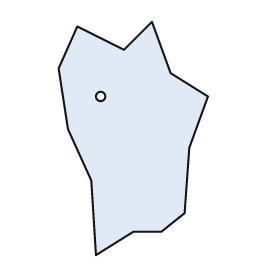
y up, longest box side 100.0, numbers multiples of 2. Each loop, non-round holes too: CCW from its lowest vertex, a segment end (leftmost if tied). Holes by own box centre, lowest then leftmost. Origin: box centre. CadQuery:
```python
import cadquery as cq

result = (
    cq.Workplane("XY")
    .moveTo(-16.0, -50.0)
    .lineTo(0.0, -40.0)
    .lineTo(12.0, -40.0)
    .lineTo(22.0, -32.0)
    .lineTo(24.0, -4.0)
    .lineTo(32.0, 18.0)
    .lineTo(16.0, 28.0)
    .lineTo(8.0, 50.0)
    .lineTo(-4.0, 38.0)
    .lineTo(-24.0, 48.0)
    .lineTo(-32.0, 30.0)
    .lineTo(-28.0, 4.0)
    .lineTo(-18.0, -18.0)
    .close()
    .moveTo(-14.0, 18.0)
    .circle(2.0)
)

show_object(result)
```